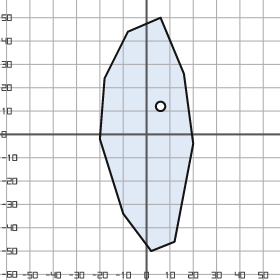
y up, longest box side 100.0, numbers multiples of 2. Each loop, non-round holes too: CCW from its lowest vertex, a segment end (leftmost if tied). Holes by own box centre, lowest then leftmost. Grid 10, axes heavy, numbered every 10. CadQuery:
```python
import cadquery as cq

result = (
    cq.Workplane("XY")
    .moveTo(2.0, -50.0)
    .lineTo(12.0, -46.0)
    .lineTo(20.0, -4.0)
    .lineTo(16.0, 26.0)
    .lineTo(6.0, 50.0)
    .lineTo(-8.0, 44.0)
    .lineTo(-18.0, 24.0)
    .lineTo(-20.0, -2.0)
    .lineTo(-10.0, -34.0)
    .close()
    .moveTo(6.0, 12.0)
    .circle(2.0)
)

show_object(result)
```